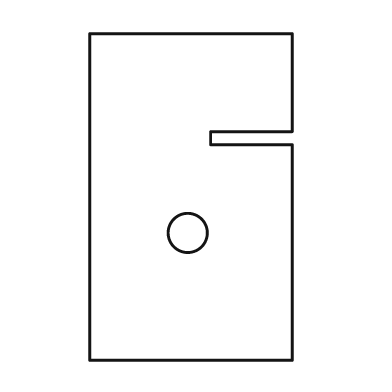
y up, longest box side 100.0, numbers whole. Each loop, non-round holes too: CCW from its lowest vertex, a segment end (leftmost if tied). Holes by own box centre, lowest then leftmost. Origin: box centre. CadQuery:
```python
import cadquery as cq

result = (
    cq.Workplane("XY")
    .moveTo(-31.0, -50.0)
    .lineTo(31.0, -50.0)
    .lineTo(31.0, 16.0)
    .lineTo(6.0, 16.0)
    .lineTo(6.0, 20.0)
    .lineTo(31.0, 20.0)
    .lineTo(31.0, 50.0)
    .lineTo(-31.0, 50.0)
    .close()
    .moveTo(-1.0, -11.0)
    .circle(6.0)
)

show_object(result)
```